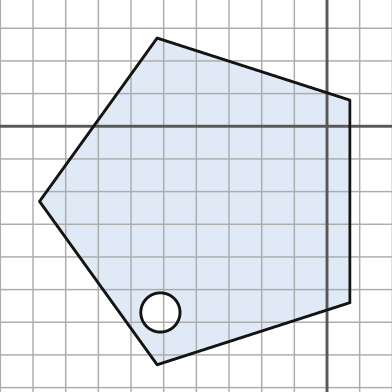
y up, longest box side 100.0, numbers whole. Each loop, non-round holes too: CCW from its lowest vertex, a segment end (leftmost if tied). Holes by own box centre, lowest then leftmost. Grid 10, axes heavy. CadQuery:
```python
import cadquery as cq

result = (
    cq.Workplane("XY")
    .moveTo(-52.0, -73.0)
    .lineTo(7.0, -54.0)
    .lineTo(7.0, 8.0)
    .lineTo(-52.0, 27.0)
    .lineTo(-88.0, -23.0)
    .close()
    .moveTo(-51.0, -57.0)
    .circle(6.0)
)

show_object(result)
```